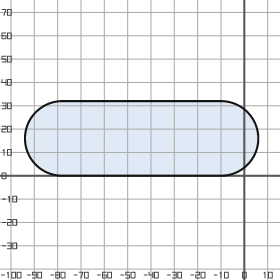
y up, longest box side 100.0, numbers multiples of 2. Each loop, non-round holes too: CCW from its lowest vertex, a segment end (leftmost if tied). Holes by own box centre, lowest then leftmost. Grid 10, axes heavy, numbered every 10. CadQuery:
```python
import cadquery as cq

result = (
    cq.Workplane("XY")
    .moveTo(-78.0, 0.0)
    .lineTo(-10.0, 0.0)
    .threePointArc((6.0, 16.0), (-10.0, 32.0))
    .lineTo(-78.0, 32.0)
    .threePointArc((-94.0, 16.0), (-78.0, 0.0))
    .close()
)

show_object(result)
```